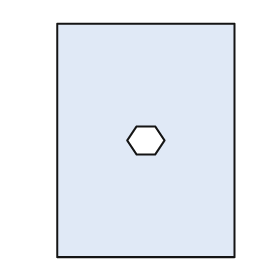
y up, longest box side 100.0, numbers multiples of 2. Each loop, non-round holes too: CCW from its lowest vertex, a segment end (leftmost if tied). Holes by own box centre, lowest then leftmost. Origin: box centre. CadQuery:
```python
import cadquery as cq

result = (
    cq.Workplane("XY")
    .moveTo(-38.0, -50.0)
    .lineTo(38.0, -50.0)
    .lineTo(38.0, 50.0)
    .lineTo(-38.0, 50.0)
    .close()
    .moveTo(-4.0, -6.0)
    .lineTo(4.0, -6.0)
    .lineTo(8.0, 0.0)
    .lineTo(4.0, 6.0)
    .lineTo(-4.0, 6.0)
    .lineTo(-8.0, 0.0)
    .close()
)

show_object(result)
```